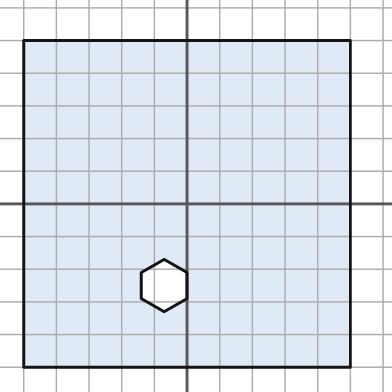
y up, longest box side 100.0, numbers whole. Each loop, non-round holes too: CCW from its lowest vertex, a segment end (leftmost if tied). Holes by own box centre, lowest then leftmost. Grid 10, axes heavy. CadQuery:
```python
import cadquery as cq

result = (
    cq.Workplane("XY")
    .moveTo(-50.0, -50.0)
    .lineTo(50.0, -50.0)
    .lineTo(50.0, 50.0)
    .lineTo(-50.0, 50.0)
    .close()
    .moveTo(-7.0, -33.0)
    .lineTo(0.0, -29.0)
    .lineTo(0.0, -21.0)
    .lineTo(-7.0, -17.0)
    .lineTo(-14.0, -21.0)
    .lineTo(-14.0, -29.0)
    .close()
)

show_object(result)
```